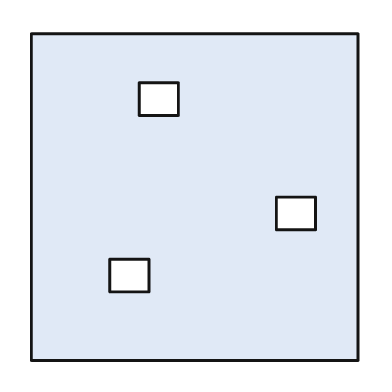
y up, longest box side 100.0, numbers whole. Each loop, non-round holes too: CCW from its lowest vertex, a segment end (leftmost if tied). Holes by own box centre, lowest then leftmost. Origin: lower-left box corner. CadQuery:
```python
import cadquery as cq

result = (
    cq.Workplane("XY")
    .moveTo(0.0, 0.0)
    .lineTo(100.0, 0.0)
    .lineTo(100.0, 100.0)
    .lineTo(0.0, 100.0)
    .close()
    .moveTo(24.0, 21.0)
    .lineTo(36.0, 21.0)
    .lineTo(36.0, 31.0)
    .lineTo(24.0, 31.0)
    .close()
    .moveTo(75.0, 40.0)
    .lineTo(87.0, 40.0)
    .lineTo(87.0, 50.0)
    .lineTo(75.0, 50.0)
    .close()
    .moveTo(33.0, 75.0)
    .lineTo(45.0, 75.0)
    .lineTo(45.0, 85.0)
    .lineTo(33.0, 85.0)
    .close()
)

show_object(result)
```